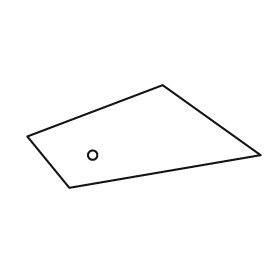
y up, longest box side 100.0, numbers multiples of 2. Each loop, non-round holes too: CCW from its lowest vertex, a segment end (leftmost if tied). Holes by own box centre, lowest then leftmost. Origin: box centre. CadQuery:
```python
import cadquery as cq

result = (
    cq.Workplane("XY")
    .moveTo(-32.0, -22.0)
    .lineTo(50.0, -8.0)
    .lineTo(8.0, 22.0)
    .lineTo(-50.0, 0.0)
    .close()
    .moveTo(-22.0, -8.0)
    .circle(2.0)
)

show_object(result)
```